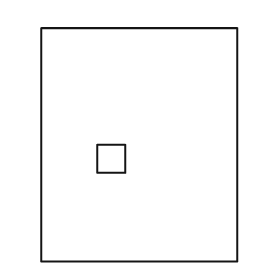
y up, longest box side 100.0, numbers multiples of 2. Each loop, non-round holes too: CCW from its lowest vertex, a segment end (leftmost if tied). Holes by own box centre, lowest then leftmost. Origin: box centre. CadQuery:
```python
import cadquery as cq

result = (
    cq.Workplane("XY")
    .moveTo(-42.0, -50.0)
    .lineTo(42.0, -50.0)
    .lineTo(42.0, 50.0)
    .lineTo(-42.0, 50.0)
    .close()
    .moveTo(-18.0, -12.0)
    .lineTo(-6.0, -12.0)
    .lineTo(-6.0, 0.0)
    .lineTo(-18.0, 0.0)
    .close()
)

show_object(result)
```